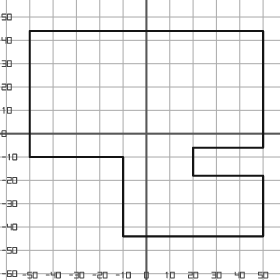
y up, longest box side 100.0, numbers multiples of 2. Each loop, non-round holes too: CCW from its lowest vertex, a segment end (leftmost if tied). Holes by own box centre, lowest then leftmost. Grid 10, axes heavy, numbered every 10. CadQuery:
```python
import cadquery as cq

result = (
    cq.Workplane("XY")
    .moveTo(-10.0, -44.0)
    .lineTo(50.0, -44.0)
    .lineTo(50.0, -18.0)
    .lineTo(20.0, -18.0)
    .lineTo(20.0, -6.0)
    .lineTo(50.0, -6.0)
    .lineTo(50.0, 44.0)
    .lineTo(-50.0, 44.0)
    .lineTo(-50.0, -10.0)
    .lineTo(-10.0, -10.0)
    .close()
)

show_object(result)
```